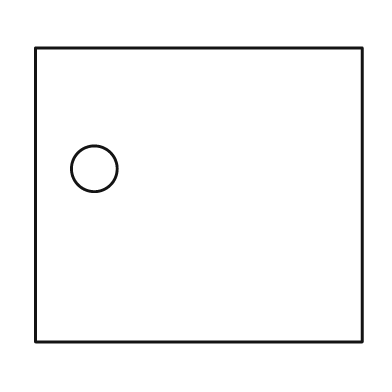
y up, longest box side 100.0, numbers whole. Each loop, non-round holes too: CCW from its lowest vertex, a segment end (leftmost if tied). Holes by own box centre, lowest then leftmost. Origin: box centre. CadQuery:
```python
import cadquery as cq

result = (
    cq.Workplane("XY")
    .moveTo(-50.0, -45.0)
    .lineTo(50.0, -45.0)
    .lineTo(50.0, 45.0)
    .lineTo(-50.0, 45.0)
    .close()
    .moveTo(-32.0, 8.0)
    .circle(7.0)
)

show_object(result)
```